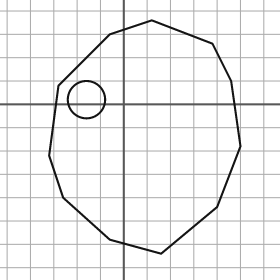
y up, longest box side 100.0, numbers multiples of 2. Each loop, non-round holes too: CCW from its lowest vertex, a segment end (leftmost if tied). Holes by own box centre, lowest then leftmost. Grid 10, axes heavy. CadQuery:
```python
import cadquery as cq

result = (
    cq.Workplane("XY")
    .moveTo(16.0, -64.0)
    .lineTo(40.0, -44.0)
    .lineTo(50.0, -18.0)
    .lineTo(46.0, 10.0)
    .lineTo(38.0, 26.0)
    .lineTo(12.0, 36.0)
    .lineTo(-6.0, 30.0)
    .lineTo(-28.0, 8.0)
    .lineTo(-32.0, -22.0)
    .lineTo(-26.0, -40.0)
    .lineTo(-6.0, -58.0)
    .close()
    .moveTo(-16.0, 2.0)
    .circle(8.0)
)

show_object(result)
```